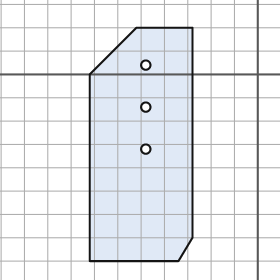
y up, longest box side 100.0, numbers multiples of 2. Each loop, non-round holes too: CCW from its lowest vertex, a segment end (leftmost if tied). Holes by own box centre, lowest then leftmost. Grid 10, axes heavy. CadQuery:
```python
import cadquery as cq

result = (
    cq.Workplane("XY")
    .moveTo(-72.0, -80.0)
    .lineTo(-34.0, -80.0)
    .lineTo(-28.0, -70.0)
    .lineTo(-28.0, 20.0)
    .lineTo(-52.0, 20.0)
    .lineTo(-72.0, 0.0)
    .close()
    .moveTo(-48.0, -32.0)
    .circle(2.0)
    .moveTo(-48.0, -14.0)
    .circle(2.0)
    .moveTo(-48.0, 4.0)
    .circle(2.0)
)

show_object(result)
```